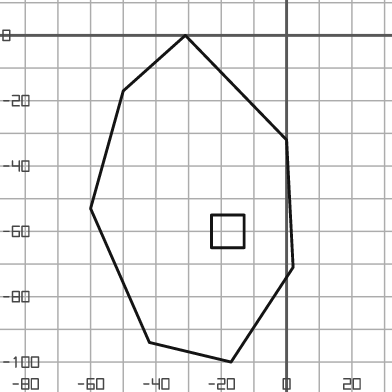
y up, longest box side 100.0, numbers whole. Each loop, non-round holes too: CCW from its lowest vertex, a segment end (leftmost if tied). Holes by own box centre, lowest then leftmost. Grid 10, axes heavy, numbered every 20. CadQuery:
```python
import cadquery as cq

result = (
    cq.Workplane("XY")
    .moveTo(-17.0, -100.0)
    .lineTo(2.0, -71.0)
    .lineTo(0.0, -32.0)
    .lineTo(-31.0, 0.0)
    .lineTo(-50.0, -17.0)
    .lineTo(-60.0, -53.0)
    .lineTo(-42.0, -94.0)
    .close()
    .moveTo(-23.0, -65.0)
    .lineTo(-13.0, -65.0)
    .lineTo(-13.0, -55.0)
    .lineTo(-23.0, -55.0)
    .close()
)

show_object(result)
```